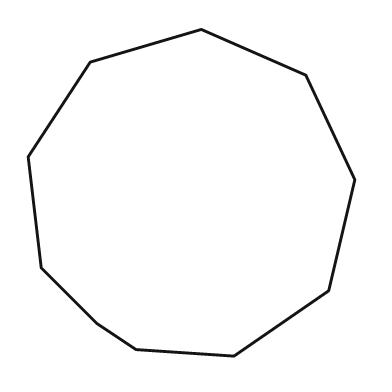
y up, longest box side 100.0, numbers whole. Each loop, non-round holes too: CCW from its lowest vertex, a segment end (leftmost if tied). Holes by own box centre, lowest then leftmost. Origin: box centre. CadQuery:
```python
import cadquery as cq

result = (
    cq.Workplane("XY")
    .moveTo(13.0, -50.0)
    .lineTo(42.0, -30.0)
    .lineTo(50.0, 4.0)
    .lineTo(35.0, 36.0)
    .lineTo(3.0, 50.0)
    .lineTo(-31.0, 40.0)
    .lineTo(-50.0, 11.0)
    .lineTo(-46.0, -23.0)
    .lineTo(-29.0, -40.0)
    .lineTo(-17.0, -48.0)
    .close()
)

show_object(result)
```